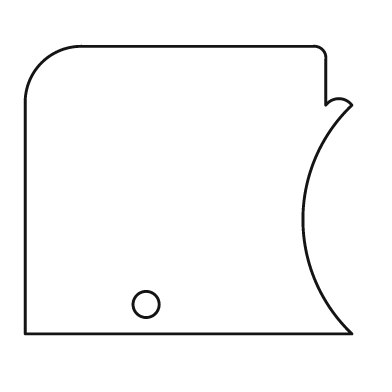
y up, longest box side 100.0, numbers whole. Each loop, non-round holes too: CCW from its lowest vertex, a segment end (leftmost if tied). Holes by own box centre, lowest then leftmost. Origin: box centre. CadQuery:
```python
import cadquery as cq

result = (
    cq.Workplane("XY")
    .moveTo(-50.0, -44.0)
    .lineTo(50.0, -44.0)
    .threePointArc((35.0, -9.0), (50.0, 26.0))
    .threePointArc((46.0, 28.0), (42.0, 26.0))
    .lineTo(42.0, 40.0)
    .threePointArc((41.0, 43.0), (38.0, 44.0))
    .lineTo(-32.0, 44.0)
    .threePointArc((-45.0, 39.0), (-50.0, 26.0))
    .close()
    .moveTo(-13.0, -35.0)
    .circle(4.0)
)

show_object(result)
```